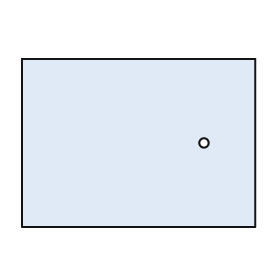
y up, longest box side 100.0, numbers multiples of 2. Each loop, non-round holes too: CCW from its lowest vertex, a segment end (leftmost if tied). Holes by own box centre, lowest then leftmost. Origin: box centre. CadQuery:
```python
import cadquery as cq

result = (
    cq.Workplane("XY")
    .moveTo(-50.0, -36.0)
    .lineTo(50.0, -36.0)
    .lineTo(50.0, 36.0)
    .lineTo(-50.0, 36.0)
    .close()
    .moveTo(28.0, 0.0)
    .circle(2.0)
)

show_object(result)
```